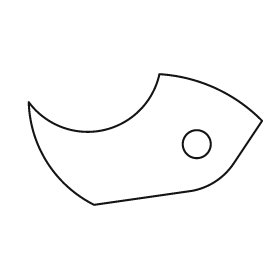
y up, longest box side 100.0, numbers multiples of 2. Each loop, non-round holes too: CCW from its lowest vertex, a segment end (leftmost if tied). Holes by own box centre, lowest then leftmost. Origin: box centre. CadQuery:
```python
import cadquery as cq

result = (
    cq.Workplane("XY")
    .moveTo(-22.0, -28.0)
    .lineTo(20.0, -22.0)
    .threePointArc((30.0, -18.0), (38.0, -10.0))
    .lineTo(50.0, 8.0)
    .threePointArc((30.0, 22.0), (6.0, 28.0))
    .threePointArc((-18.0, 4.0), (-50.0, 16.0))
    .threePointArc((-42.0, -10.0), (-22.0, -28.0))
    .close()
    .moveTo(22.0, -2.0)
    .circle(6.0)
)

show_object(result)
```